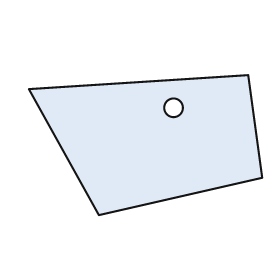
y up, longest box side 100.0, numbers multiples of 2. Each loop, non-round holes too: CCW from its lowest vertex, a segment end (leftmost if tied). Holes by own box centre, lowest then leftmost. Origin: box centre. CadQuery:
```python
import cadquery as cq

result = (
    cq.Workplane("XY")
    .moveTo(-20.0, -30.0)
    .lineTo(50.0, -14.0)
    .lineTo(44.0, 30.0)
    .lineTo(-50.0, 24.0)
    .close()
    .moveTo(12.0, 16.0)
    .circle(4.0)
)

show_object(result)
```